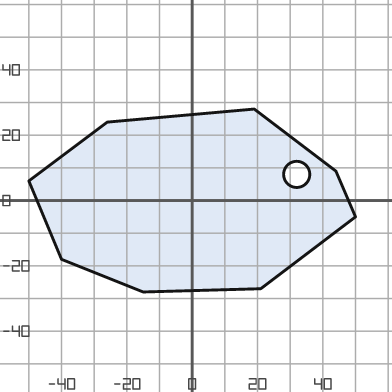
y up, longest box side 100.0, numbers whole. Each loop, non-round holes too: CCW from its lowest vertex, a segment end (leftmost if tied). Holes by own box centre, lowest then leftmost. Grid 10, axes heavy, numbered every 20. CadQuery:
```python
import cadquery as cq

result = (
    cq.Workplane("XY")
    .moveTo(-15.0, -28.0)
    .lineTo(21.0, -27.0)
    .lineTo(50.0, -5.0)
    .lineTo(44.0, 9.0)
    .lineTo(19.0, 28.0)
    .lineTo(-26.0, 24.0)
    .lineTo(-50.0, 6.0)
    .lineTo(-40.0, -18.0)
    .close()
    .moveTo(32.0, 8.0)
    .circle(4.0)
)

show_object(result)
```